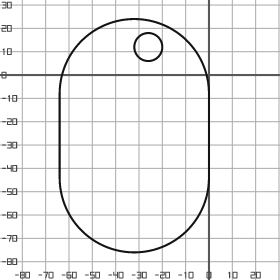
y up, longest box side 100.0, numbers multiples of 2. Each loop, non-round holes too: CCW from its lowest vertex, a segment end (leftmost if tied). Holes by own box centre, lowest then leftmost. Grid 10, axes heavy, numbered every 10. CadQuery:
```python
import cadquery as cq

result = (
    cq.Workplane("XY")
    .moveTo(-64.0, -44.0)
    .threePointArc((-32.0, -76.0), (0.0, -44.0))
    .lineTo(0.0, -8.0)
    .threePointArc((-32.0, 24.0), (-64.0, -8.0))
    .close()
    .moveTo(-26.0, 12.0)
    .circle(6.0)
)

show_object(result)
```